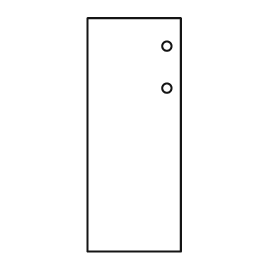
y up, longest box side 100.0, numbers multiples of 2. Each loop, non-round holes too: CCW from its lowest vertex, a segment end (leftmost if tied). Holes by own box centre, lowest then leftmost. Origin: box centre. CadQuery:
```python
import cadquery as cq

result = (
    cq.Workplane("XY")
    .moveTo(-20.0, -50.0)
    .lineTo(20.0, -50.0)
    .lineTo(20.0, 50.0)
    .lineTo(-20.0, 50.0)
    .close()
    .moveTo(14.0, 20.0)
    .circle(2.0)
    .moveTo(14.0, 38.0)
    .circle(2.0)
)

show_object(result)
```